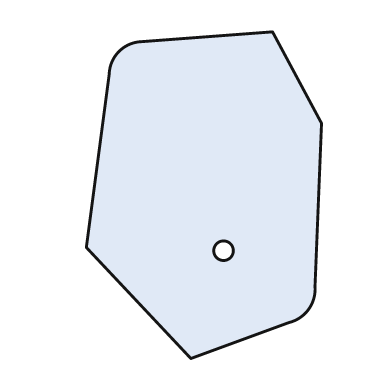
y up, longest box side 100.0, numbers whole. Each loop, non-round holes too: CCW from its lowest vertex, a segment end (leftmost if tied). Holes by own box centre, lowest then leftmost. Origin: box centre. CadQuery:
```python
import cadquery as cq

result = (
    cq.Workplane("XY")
    .moveTo(-4.0, -50.0)
    .lineTo(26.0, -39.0)
    .threePointArc((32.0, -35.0), (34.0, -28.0))
    .lineTo(36.0, 22.0)
    .lineTo(21.0, 50.0)
    .lineTo(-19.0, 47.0)
    .threePointArc((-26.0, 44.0), (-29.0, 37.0))
    .lineTo(-36.0, -16.0)
    .close()
    .moveTo(6.0, -17.0)
    .circle(3.0)
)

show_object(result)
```